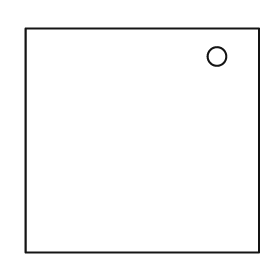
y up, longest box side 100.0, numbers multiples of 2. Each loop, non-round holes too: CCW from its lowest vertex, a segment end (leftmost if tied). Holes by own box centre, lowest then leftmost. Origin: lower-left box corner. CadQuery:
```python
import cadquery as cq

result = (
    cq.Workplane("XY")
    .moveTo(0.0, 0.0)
    .lineTo(100.0, 0.0)
    .lineTo(100.0, 96.0)
    .lineTo(0.0, 96.0)
    .close()
    .moveTo(82.0, 84.0)
    .circle(4.0)
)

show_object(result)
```